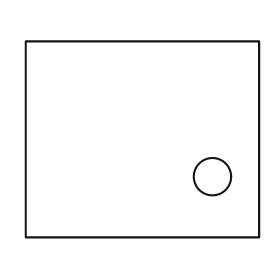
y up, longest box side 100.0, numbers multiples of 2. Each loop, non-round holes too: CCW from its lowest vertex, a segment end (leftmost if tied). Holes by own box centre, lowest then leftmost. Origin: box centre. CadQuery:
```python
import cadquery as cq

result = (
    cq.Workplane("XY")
    .moveTo(-50.0, -42.0)
    .lineTo(50.0, -42.0)
    .lineTo(50.0, 42.0)
    .lineTo(-50.0, 42.0)
    .close()
    .moveTo(30.0, -16.0)
    .circle(8.0)
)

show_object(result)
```